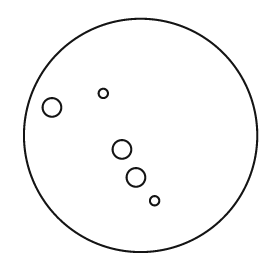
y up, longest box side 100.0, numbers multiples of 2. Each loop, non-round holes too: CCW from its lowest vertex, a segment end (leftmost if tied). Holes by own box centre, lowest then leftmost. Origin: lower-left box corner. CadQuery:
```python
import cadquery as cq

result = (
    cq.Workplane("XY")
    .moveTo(50.0, 50.0)
    .circle(50.0)
    .moveTo(56.0, 22.0)
    .circle(2.0)
    .moveTo(48.0, 32.0)
    .circle(4.0)
    .moveTo(42.0, 44.0)
    .circle(4.0)
    .moveTo(12.0, 62.0)
    .circle(4.0)
    .moveTo(34.0, 68.0)
    .circle(2.0)
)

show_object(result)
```